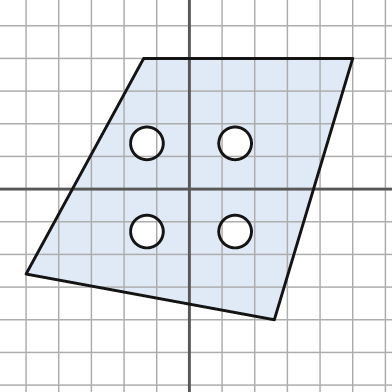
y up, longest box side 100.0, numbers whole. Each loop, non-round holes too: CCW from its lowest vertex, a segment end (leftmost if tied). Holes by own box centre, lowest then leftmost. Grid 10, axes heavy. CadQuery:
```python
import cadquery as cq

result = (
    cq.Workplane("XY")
    .moveTo(26.0, -40.0)
    .lineTo(50.0, 40.0)
    .lineTo(-14.0, 40.0)
    .lineTo(-50.0, -26.0)
    .close()
    .moveTo(-13.0, -13.0)
    .circle(5.0)
    .moveTo(14.0, -13.0)
    .circle(5.0)
    .moveTo(-13.0, 14.0)
    .circle(5.0)
    .moveTo(14.0, 14.0)
    .circle(5.0)
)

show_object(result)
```